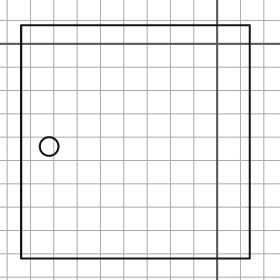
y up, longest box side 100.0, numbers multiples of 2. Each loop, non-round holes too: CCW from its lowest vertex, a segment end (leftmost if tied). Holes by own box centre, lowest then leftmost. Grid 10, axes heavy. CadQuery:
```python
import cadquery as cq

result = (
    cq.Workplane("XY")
    .moveTo(-84.0, -92.0)
    .lineTo(14.0, -92.0)
    .lineTo(14.0, 8.0)
    .lineTo(-84.0, 8.0)
    .close()
    .moveTo(-72.0, -44.0)
    .circle(4.0)
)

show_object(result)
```